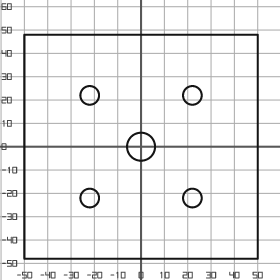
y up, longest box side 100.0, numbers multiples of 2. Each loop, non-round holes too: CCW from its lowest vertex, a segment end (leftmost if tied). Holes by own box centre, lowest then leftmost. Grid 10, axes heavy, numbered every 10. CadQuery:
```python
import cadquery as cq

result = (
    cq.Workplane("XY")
    .moveTo(-50.0, -48.0)
    .lineTo(50.0, -48.0)
    .lineTo(50.0, 48.0)
    .lineTo(-50.0, 48.0)
    .close()
    .moveTo(-22.0, -22.0)
    .circle(4.0)
    .moveTo(22.0, -22.0)
    .circle(4.0)
    .moveTo(0.0, 0.0)
    .circle(6.0)
    .moveTo(-22.0, 22.0)
    .circle(4.0)
    .moveTo(22.0, 22.0)
    .circle(4.0)
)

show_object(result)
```